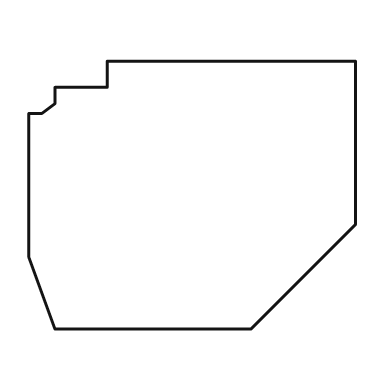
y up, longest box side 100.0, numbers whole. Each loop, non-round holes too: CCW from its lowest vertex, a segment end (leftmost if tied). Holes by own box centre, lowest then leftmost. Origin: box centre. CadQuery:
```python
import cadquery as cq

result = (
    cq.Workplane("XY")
    .moveTo(-42.0, -41.0)
    .lineTo(18.0, -41.0)
    .lineTo(50.0, -9.0)
    .lineTo(50.0, 41.0)
    .lineTo(-26.0, 41.0)
    .lineTo(-26.0, 33.0)
    .lineTo(-42.0, 33.0)
    .lineTo(-42.0, 28.0)
    .lineTo(-46.0, 25.0)
    .lineTo(-50.0, 25.0)
    .lineTo(-50.0, -19.0)
    .close()
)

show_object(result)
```